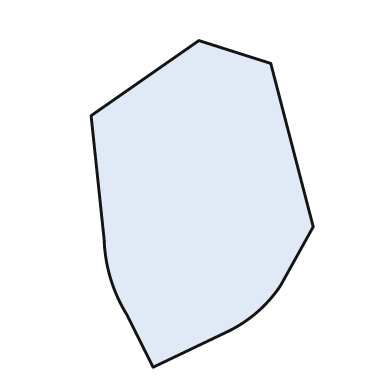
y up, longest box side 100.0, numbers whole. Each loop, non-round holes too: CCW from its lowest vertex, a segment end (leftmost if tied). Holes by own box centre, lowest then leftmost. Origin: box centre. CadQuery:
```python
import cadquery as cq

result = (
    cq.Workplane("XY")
    .moveTo(-15.0, -50.0)
    .lineTo(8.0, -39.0)
    .threePointArc((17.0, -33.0), (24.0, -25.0))
    .lineTo(34.0, -7.0)
    .lineTo(21.0, 43.0)
    .lineTo(-1.0, 50.0)
    .lineTo(-34.0, 27.0)
    .lineTo(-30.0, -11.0)
    .threePointArc((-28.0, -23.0), (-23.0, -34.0))
    .close()
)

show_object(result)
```